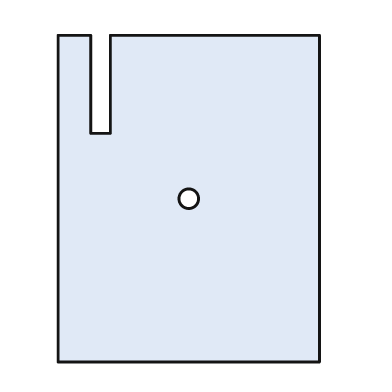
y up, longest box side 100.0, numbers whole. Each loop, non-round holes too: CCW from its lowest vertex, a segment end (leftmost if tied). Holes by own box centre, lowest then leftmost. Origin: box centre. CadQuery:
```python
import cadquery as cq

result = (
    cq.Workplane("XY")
    .moveTo(-40.0, -50.0)
    .lineTo(40.0, -50.0)
    .lineTo(40.0, 50.0)
    .lineTo(-24.0, 50.0)
    .lineTo(-24.0, 20.0)
    .lineTo(-30.0, 20.0)
    .lineTo(-30.0, 50.0)
    .lineTo(-40.0, 50.0)
    .close()
    .moveTo(0.0, 0.0)
    .circle(3.0)
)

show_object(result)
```